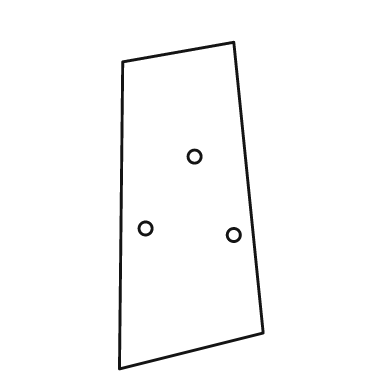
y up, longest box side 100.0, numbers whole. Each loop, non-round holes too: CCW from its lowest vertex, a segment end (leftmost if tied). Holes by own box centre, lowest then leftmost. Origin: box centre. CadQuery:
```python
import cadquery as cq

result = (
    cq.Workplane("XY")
    .moveTo(-22.0, -50.0)
    .lineTo(22.0, -39.0)
    .lineTo(13.0, 50.0)
    .lineTo(-21.0, 44.0)
    .close()
    .moveTo(13.0, -9.0)
    .circle(2.0)
    .moveTo(-14.0, -7.0)
    .circle(2.0)
    .moveTo(1.0, 15.0)
    .circle(2.0)
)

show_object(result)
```